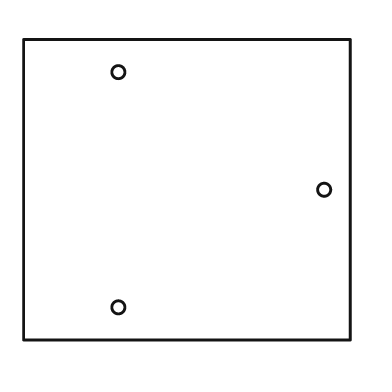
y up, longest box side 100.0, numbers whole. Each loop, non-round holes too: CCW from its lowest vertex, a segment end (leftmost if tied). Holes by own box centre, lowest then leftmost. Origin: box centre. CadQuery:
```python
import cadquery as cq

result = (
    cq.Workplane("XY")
    .moveTo(-50.0, -46.0)
    .lineTo(50.0, -46.0)
    .lineTo(50.0, 46.0)
    .lineTo(-50.0, 46.0)
    .close()
    .moveTo(-21.0, -36.0)
    .circle(2.0)
    .moveTo(42.0, 0.0)
    .circle(2.0)
    .moveTo(-21.0, 36.0)
    .circle(2.0)
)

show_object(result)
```